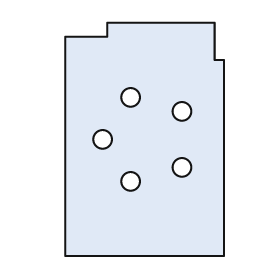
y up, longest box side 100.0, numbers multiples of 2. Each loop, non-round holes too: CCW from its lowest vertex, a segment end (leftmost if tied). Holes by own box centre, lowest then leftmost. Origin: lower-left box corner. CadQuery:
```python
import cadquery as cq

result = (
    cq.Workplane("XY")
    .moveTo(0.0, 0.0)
    .lineTo(68.0, 0.0)
    .lineTo(68.0, 84.0)
    .lineTo(64.0, 84.0)
    .lineTo(64.0, 100.0)
    .lineTo(18.0, 100.0)
    .lineTo(18.0, 94.0)
    .lineTo(0.0, 94.0)
    .close()
    .moveTo(28.0, 32.0)
    .circle(4.0)
    .moveTo(50.0, 38.0)
    .circle(4.0)
    .moveTo(16.0, 50.0)
    .circle(4.0)
    .moveTo(50.0, 62.0)
    .circle(4.0)
    .moveTo(28.0, 68.0)
    .circle(4.0)
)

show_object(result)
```